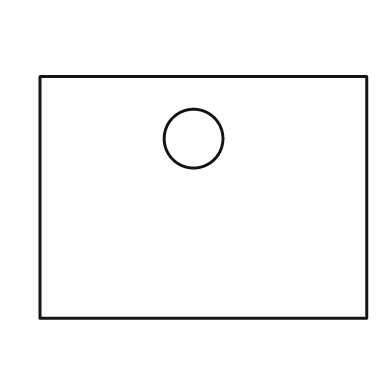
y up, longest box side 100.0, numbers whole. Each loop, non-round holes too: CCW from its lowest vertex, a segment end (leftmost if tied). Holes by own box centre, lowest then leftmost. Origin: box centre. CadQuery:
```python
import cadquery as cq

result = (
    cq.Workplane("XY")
    .moveTo(-50.0, -37.0)
    .lineTo(50.0, -37.0)
    .lineTo(50.0, 37.0)
    .lineTo(-50.0, 37.0)
    .close()
    .moveTo(-3.0, 18.0)
    .circle(9.0)
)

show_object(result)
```